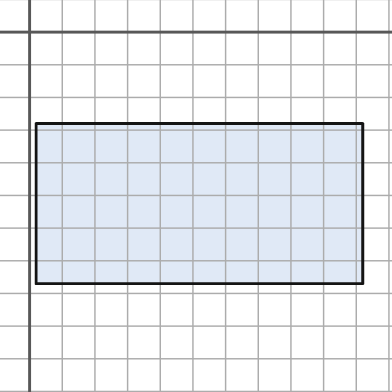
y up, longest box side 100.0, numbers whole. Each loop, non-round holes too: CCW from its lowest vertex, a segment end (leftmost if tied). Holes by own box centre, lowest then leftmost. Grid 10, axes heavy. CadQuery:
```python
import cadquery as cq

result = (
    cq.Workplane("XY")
    .moveTo(2.0, -77.0)
    .lineTo(102.0, -77.0)
    .lineTo(102.0, -28.0)
    .lineTo(2.0, -28.0)
    .close()
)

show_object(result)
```